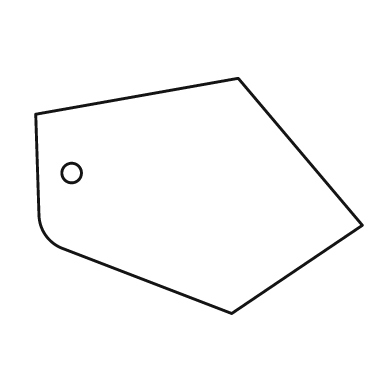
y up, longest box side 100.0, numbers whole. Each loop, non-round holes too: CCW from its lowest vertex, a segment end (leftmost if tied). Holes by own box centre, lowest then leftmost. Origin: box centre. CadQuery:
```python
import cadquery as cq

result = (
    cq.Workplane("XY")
    .moveTo(10.0, -36.0)
    .lineTo(50.0, -9.0)
    .lineTo(12.0, 36.0)
    .lineTo(-50.0, 25.0)
    .lineTo(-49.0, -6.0)
    .threePointArc((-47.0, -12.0), (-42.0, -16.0))
    .close()
    .moveTo(-39.0, 7.0)
    .circle(3.0)
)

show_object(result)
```